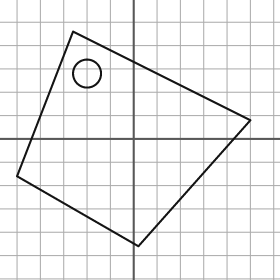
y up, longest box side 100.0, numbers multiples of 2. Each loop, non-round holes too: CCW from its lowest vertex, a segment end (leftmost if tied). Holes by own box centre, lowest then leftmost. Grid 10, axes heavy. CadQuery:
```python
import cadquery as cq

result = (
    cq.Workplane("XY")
    .moveTo(2.0, -46.0)
    .lineTo(50.0, 8.0)
    .lineTo(-26.0, 46.0)
    .lineTo(-50.0, -16.0)
    .close()
    .moveTo(-20.0, 28.0)
    .circle(6.0)
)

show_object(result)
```